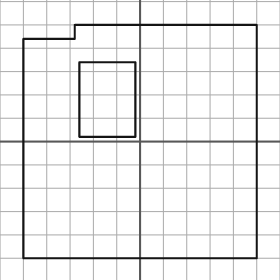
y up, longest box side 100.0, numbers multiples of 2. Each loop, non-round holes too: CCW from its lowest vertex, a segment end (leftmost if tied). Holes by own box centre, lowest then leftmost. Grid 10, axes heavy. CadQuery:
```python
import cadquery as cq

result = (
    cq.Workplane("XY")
    .moveTo(-50.0, -50.0)
    .lineTo(50.0, -50.0)
    .lineTo(50.0, 50.0)
    .lineTo(-28.0, 50.0)
    .lineTo(-28.0, 44.0)
    .lineTo(-50.0, 44.0)
    .close()
    .moveTo(-26.0, 2.0)
    .lineTo(-2.0, 2.0)
    .lineTo(-2.0, 34.0)
    .lineTo(-26.0, 34.0)
    .close()
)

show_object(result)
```